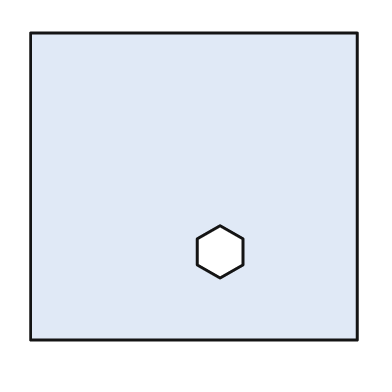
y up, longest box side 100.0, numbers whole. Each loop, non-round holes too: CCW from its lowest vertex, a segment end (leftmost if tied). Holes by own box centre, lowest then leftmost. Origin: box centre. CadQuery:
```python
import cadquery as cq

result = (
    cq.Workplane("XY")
    .moveTo(-50.0, -47.0)
    .lineTo(50.0, -47.0)
    .lineTo(50.0, 47.0)
    .lineTo(-50.0, 47.0)
    .close()
    .moveTo(8.0, -28.0)
    .lineTo(15.0, -24.0)
    .lineTo(15.0, -16.0)
    .lineTo(8.0, -12.0)
    .lineTo(1.0, -16.0)
    .lineTo(1.0, -24.0)
    .close()
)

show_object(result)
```